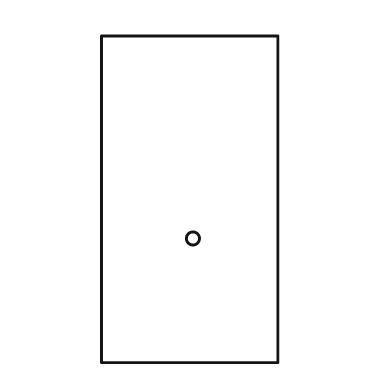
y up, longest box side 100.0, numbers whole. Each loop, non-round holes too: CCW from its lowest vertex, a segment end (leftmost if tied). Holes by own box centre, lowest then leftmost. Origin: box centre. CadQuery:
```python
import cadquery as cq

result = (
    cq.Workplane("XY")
    .moveTo(-27.0, -50.0)
    .lineTo(27.0, -50.0)
    .lineTo(27.0, 50.0)
    .lineTo(-27.0, 50.0)
    .close()
    .moveTo(1.0, -12.0)
    .circle(2.0)
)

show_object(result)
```